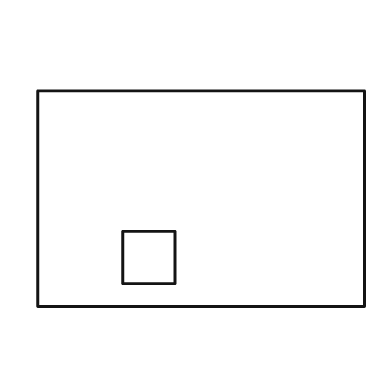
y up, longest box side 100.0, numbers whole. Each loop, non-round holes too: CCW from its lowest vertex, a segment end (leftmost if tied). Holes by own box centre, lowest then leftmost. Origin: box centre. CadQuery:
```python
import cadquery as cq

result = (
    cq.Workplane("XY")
    .moveTo(-50.0, -33.0)
    .lineTo(50.0, -33.0)
    .lineTo(50.0, 33.0)
    .lineTo(-50.0, 33.0)
    .close()
    .moveTo(-24.0, -26.0)
    .lineTo(-8.0, -26.0)
    .lineTo(-8.0, -10.0)
    .lineTo(-24.0, -10.0)
    .close()
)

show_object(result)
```